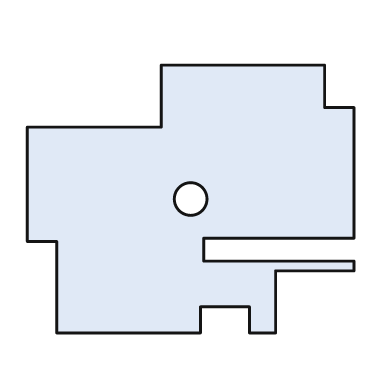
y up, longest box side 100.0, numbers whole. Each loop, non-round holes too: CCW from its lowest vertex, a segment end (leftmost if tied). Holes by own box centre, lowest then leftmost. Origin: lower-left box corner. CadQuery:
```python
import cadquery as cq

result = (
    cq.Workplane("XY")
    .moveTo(9.0, 0.0)
    .lineTo(53.0, 0.0)
    .lineTo(53.0, 8.0)
    .lineTo(68.0, 8.0)
    .lineTo(68.0, 0.0)
    .lineTo(76.0, 0.0)
    .lineTo(76.0, 19.0)
    .lineTo(100.0, 19.0)
    .lineTo(100.0, 22.0)
    .lineTo(54.0, 22.0)
    .lineTo(54.0, 29.0)
    .lineTo(100.0, 29.0)
    .lineTo(100.0, 69.0)
    .lineTo(91.0, 69.0)
    .lineTo(91.0, 82.0)
    .lineTo(41.0, 82.0)
    .lineTo(41.0, 63.0)
    .lineTo(0.0, 63.0)
    .lineTo(0.0, 28.0)
    .lineTo(9.0, 28.0)
    .close()
    .moveTo(50.0, 41.0)
    .circle(5.0)
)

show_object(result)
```